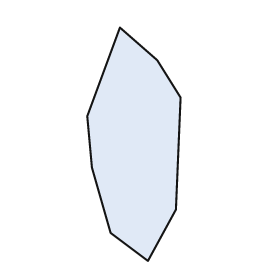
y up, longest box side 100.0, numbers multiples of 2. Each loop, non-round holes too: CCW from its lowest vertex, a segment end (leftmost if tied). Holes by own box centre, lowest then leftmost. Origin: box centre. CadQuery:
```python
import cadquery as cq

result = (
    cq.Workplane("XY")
    .moveTo(6.0, -50.0)
    .lineTo(18.0, -28.0)
    .lineTo(20.0, 20.0)
    .lineTo(10.0, 36.0)
    .lineTo(-6.0, 50.0)
    .lineTo(-20.0, 12.0)
    .lineTo(-18.0, -10.0)
    .lineTo(-10.0, -38.0)
    .close()
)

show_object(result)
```